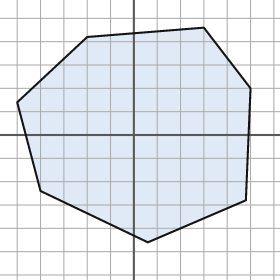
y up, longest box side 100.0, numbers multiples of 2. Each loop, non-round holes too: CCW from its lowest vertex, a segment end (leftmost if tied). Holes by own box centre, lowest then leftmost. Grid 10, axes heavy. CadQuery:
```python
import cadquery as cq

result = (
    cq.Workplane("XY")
    .moveTo(6.0, -46.0)
    .lineTo(48.0, -28.0)
    .lineTo(50.0, 20.0)
    .lineTo(30.0, 46.0)
    .lineTo(-20.0, 42.0)
    .lineTo(-50.0, 14.0)
    .lineTo(-40.0, -24.0)
    .close()
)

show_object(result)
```